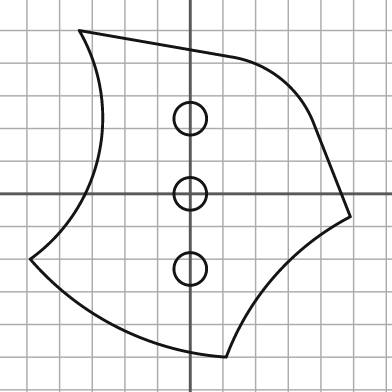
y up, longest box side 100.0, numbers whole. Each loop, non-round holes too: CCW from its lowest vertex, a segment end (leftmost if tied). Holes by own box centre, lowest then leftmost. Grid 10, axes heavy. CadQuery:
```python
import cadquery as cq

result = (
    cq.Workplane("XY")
    .moveTo(11.0, -50.0)
    .threePointArc((26.0, -25.0), (49.0, -7.0))
    .lineTo(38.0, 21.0)
    .threePointArc((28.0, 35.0), (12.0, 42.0))
    .lineTo(-34.0, 50.0)
    .threePointArc((-28.0, 12.0), (-49.0, -20.0))
    .threePointArc((-22.0, -41.0), (11.0, -50.0))
    .close()
    .moveTo(0.0, -23.0)
    .circle(5.0)
    .moveTo(0.0, 0.0)
    .circle(5.0)
    .moveTo(0.0, 23.0)
    .circle(5.0)
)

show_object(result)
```